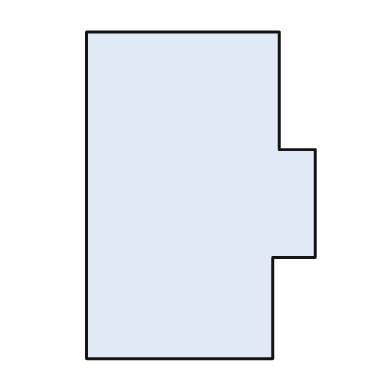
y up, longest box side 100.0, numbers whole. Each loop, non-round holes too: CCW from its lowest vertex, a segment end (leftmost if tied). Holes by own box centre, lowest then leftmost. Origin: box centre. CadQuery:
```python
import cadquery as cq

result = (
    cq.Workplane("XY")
    .moveTo(-35.0, -50.0)
    .lineTo(22.0, -50.0)
    .lineTo(22.0, -19.0)
    .lineTo(35.0, -19.0)
    .lineTo(35.0, 14.0)
    .lineTo(24.0, 14.0)
    .lineTo(24.0, 50.0)
    .lineTo(-35.0, 50.0)
    .close()
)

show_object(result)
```